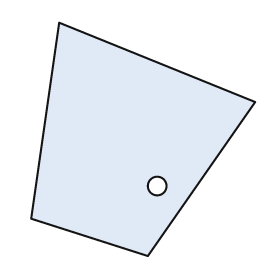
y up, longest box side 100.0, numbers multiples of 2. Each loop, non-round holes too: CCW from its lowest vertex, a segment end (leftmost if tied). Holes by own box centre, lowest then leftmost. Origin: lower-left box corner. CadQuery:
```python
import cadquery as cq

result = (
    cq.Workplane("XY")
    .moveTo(50.0, 0.0)
    .lineTo(96.0, 66.0)
    .lineTo(12.0, 100.0)
    .lineTo(0.0, 16.0)
    .close()
    .moveTo(54.0, 30.0)
    .circle(4.0)
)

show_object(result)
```